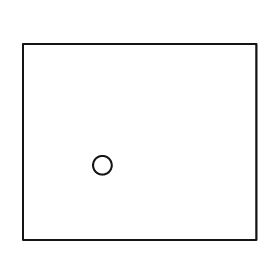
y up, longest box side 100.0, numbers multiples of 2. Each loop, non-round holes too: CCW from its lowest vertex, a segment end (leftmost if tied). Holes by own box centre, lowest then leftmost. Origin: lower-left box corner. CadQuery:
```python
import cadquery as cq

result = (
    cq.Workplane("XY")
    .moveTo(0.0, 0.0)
    .lineTo(100.0, 0.0)
    .lineTo(100.0, 84.0)
    .lineTo(0.0, 84.0)
    .close()
    .moveTo(34.0, 32.0)
    .circle(4.0)
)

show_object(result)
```